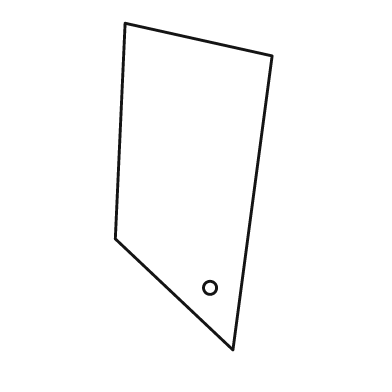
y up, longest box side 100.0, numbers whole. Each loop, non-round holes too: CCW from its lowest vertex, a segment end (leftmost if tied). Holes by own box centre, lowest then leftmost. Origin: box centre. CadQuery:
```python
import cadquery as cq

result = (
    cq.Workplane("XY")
    .moveTo(12.0, -50.0)
    .lineTo(24.0, 40.0)
    .lineTo(-21.0, 50.0)
    .lineTo(-24.0, -16.0)
    .close()
    .moveTo(5.0, -31.0)
    .circle(2.0)
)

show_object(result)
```